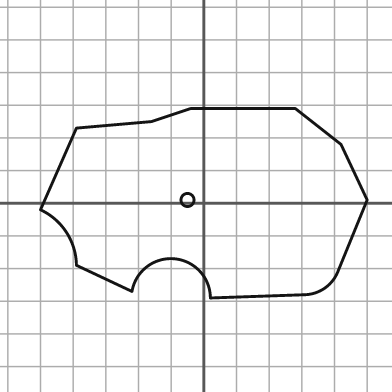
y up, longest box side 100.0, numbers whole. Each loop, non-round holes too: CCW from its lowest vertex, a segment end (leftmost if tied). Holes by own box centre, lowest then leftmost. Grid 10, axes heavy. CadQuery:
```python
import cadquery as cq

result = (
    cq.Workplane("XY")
    .moveTo(2.0, -29.0)
    .lineTo(31.0, -28.0)
    .threePointArc((37.0, -26.0), (41.0, -21.0))
    .lineTo(50.0, 1.0)
    .lineTo(42.0, 18.0)
    .lineTo(28.0, 29.0)
    .lineTo(-4.0, 29.0)
    .lineTo(-16.0, 25.0)
    .lineTo(-39.0, 23.0)
    .lineTo(-50.0, -2.0)
    .threePointArc((-42.0, -9.0), (-39.0, -19.0))
    .lineTo(-22.0, -27.0)
    .threePointArc((-9.0, -17.0), (2.0, -29.0))
    .close()
    .moveTo(-5.0, 1.0)
    .circle(2.0)
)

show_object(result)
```